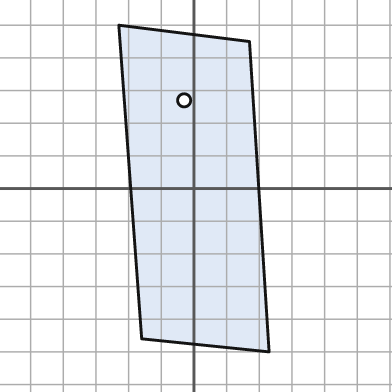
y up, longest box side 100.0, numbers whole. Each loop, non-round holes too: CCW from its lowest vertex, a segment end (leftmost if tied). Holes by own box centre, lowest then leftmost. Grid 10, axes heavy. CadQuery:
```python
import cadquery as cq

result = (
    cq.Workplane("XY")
    .moveTo(23.0, -50.0)
    .lineTo(17.0, 45.0)
    .lineTo(-23.0, 50.0)
    .lineTo(-16.0, -46.0)
    .close()
    .moveTo(-3.0, 27.0)
    .circle(2.0)
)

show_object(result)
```